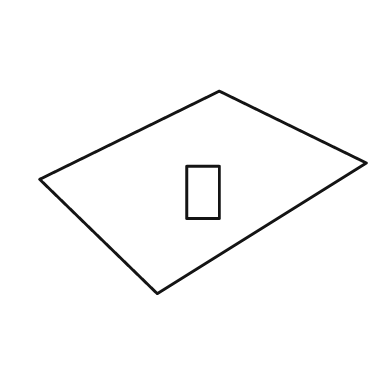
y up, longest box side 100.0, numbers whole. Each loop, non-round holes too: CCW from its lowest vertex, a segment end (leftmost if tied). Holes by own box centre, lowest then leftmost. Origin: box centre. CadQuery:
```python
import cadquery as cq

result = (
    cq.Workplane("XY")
    .moveTo(-14.0, -31.0)
    .lineTo(50.0, 9.0)
    .lineTo(5.0, 31.0)
    .lineTo(-50.0, 4.0)
    .close()
    .moveTo(-5.0, -8.0)
    .lineTo(5.0, -8.0)
    .lineTo(5.0, 8.0)
    .lineTo(-5.0, 8.0)
    .close()
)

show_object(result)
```